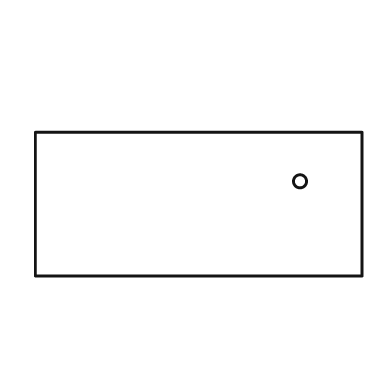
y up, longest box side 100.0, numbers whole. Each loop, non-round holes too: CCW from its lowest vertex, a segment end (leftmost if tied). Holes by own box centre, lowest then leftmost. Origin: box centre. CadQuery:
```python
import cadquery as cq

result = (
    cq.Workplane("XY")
    .moveTo(-50.0, -22.0)
    .lineTo(50.0, -22.0)
    .lineTo(50.0, 22.0)
    .lineTo(-50.0, 22.0)
    .close()
    .moveTo(31.0, 7.0)
    .circle(2.0)
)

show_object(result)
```